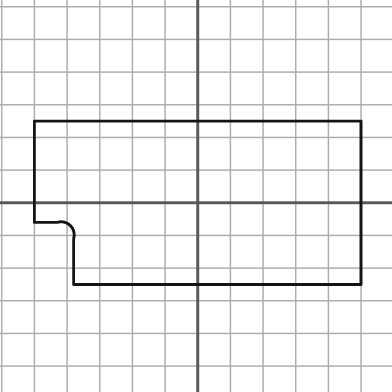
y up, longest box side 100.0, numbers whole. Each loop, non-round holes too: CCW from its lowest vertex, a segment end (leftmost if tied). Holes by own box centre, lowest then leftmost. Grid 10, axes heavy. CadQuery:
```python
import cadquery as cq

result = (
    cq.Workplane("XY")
    .moveTo(-38.0, -25.0)
    .lineTo(50.0, -25.0)
    .lineTo(50.0, 25.0)
    .lineTo(-50.0, 25.0)
    .lineTo(-50.0, -6.0)
    .lineTo(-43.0, -6.0)
    .threePointArc((-39.0, -7.0), (-38.0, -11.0))
    .close()
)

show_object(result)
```